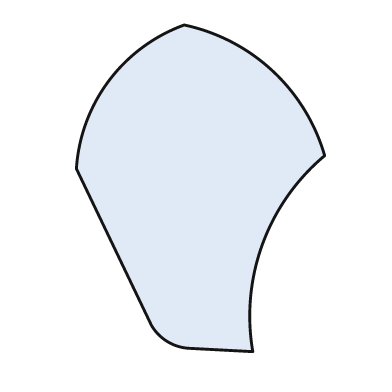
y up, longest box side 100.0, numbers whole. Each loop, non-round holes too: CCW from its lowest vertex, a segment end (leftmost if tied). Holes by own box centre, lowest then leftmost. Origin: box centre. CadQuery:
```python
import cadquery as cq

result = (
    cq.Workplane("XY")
    .moveTo(16.0, -50.0)
    .threePointArc((19.0, -17.0), (38.0, 10.0))
    .threePointArc((22.0, 36.0), (-5.0, 50.0))
    .threePointArc((-28.0, 33.0), (-38.0, 6.0))
    .lineTo(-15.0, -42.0)
    .threePointArc((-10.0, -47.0), (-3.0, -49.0))
    .close()
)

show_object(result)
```